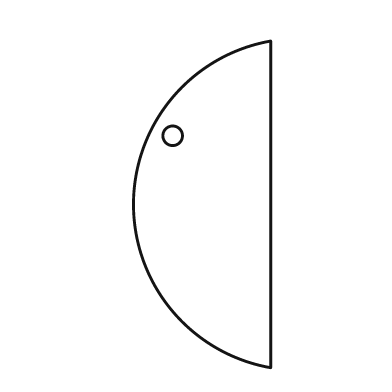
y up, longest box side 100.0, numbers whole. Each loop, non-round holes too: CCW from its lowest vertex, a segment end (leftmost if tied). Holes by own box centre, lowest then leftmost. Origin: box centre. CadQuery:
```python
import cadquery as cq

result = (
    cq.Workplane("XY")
    .moveTo(21.0, -50.0)
    .lineTo(21.0, 50.0)
    .threePointArc((-21.0, 0.0), (21.0, -50.0))
    .close()
    .moveTo(-9.0, 21.0)
    .circle(3.0)
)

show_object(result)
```